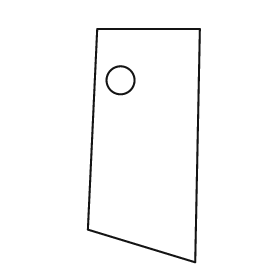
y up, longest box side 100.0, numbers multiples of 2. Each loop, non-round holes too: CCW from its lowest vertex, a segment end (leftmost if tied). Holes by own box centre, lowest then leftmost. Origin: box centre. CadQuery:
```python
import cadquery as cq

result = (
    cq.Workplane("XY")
    .moveTo(22.0, -50.0)
    .lineTo(24.0, 50.0)
    .lineTo(-20.0, 50.0)
    .lineTo(-24.0, -36.0)
    .close()
    .moveTo(-10.0, 28.0)
    .circle(6.0)
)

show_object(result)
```